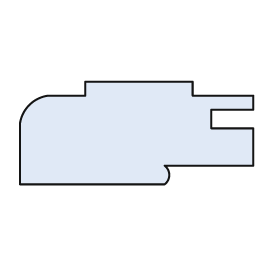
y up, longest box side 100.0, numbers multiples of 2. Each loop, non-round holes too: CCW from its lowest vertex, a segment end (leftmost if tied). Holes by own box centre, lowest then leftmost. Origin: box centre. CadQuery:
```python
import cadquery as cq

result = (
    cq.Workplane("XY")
    .moveTo(-50.0, -22.0)
    .lineTo(12.0, -22.0)
    .threePointArc((14.0, -18.0), (12.0, -14.0))
    .lineTo(50.0, -14.0)
    .lineTo(50.0, 2.0)
    .lineTo(32.0, 2.0)
    .lineTo(32.0, 10.0)
    .lineTo(50.0, 10.0)
    .lineTo(50.0, 16.0)
    .lineTo(24.0, 16.0)
    .lineTo(24.0, 22.0)
    .lineTo(-22.0, 22.0)
    .lineTo(-22.0, 16.0)
    .lineTo(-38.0, 16.0)
    .threePointArc((-46.0, 12.0), (-50.0, 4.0))
    .close()
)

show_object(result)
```